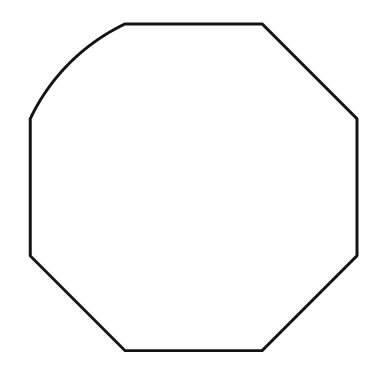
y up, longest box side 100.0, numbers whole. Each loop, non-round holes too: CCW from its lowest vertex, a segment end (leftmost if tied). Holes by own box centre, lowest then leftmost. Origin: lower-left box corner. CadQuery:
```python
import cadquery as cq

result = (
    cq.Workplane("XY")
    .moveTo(29.0, 0.0)
    .lineTo(71.0, 0.0)
    .lineTo(100.0, 29.0)
    .lineTo(100.0, 71.0)
    .lineTo(71.0, 100.0)
    .lineTo(29.0, 100.0)
    .threePointArc((12.0, 88.0), (0.0, 71.0))
    .lineTo(0.0, 29.0)
    .close()
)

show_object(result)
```